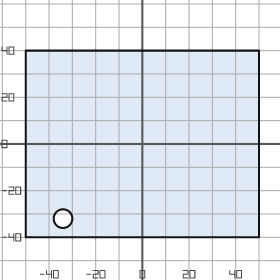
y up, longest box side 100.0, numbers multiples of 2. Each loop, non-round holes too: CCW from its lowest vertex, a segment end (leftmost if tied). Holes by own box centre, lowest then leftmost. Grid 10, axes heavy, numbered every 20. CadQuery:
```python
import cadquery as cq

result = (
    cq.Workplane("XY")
    .moveTo(-50.0, -40.0)
    .lineTo(50.0, -40.0)
    .lineTo(50.0, 40.0)
    .lineTo(-50.0, 40.0)
    .close()
    .moveTo(-34.0, -32.0)
    .circle(4.0)
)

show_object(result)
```